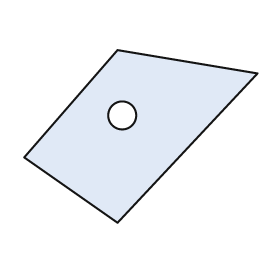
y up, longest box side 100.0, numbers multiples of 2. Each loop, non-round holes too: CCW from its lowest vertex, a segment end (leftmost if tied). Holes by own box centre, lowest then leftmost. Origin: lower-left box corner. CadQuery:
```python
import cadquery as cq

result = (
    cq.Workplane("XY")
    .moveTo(40.0, 0.0)
    .lineTo(100.0, 64.0)
    .lineTo(40.0, 74.0)
    .lineTo(0.0, 28.0)
    .close()
    .moveTo(42.0, 46.0)
    .circle(6.0)
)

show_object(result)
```